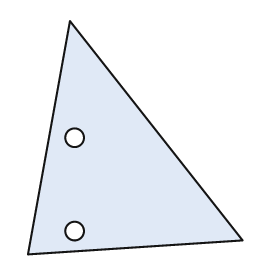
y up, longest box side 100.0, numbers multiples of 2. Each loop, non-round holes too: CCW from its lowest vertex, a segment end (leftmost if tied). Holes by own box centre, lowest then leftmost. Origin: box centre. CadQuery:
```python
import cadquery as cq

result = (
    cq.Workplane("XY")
    .moveTo(-46.0, -50.0)
    .lineTo(46.0, -44.0)
    .lineTo(-28.0, 50.0)
    .close()
    .moveTo(-26.0, -40.0)
    .circle(4.0)
    .moveTo(-26.0, 0.0)
    .circle(4.0)
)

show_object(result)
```